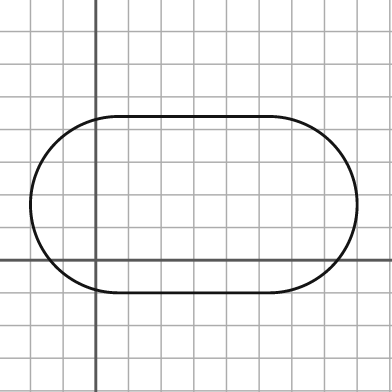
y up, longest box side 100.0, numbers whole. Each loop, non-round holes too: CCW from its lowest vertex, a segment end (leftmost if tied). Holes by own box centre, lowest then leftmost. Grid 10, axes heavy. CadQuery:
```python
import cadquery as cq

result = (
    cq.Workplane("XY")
    .moveTo(7.0, -10.0)
    .lineTo(53.0, -10.0)
    .threePointArc((80.0, 17.0), (53.0, 44.0))
    .lineTo(7.0, 44.0)
    .threePointArc((-20.0, 17.0), (7.0, -10.0))
    .close()
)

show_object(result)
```